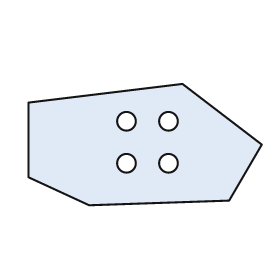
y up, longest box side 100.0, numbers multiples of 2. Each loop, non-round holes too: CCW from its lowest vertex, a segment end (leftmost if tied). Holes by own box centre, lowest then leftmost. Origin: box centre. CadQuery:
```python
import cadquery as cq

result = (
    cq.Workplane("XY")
    .moveTo(-24.0, -26.0)
    .lineTo(36.0, -24.0)
    .lineTo(50.0, 0.0)
    .lineTo(16.0, 26.0)
    .lineTo(-50.0, 18.0)
    .lineTo(-50.0, -14.0)
    .close()
    .moveTo(-8.0, -8.0)
    .circle(4.0)
    .moveTo(10.0, -8.0)
    .circle(4.0)
    .moveTo(-8.0, 10.0)
    .circle(4.0)
    .moveTo(10.0, 10.0)
    .circle(4.0)
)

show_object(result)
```